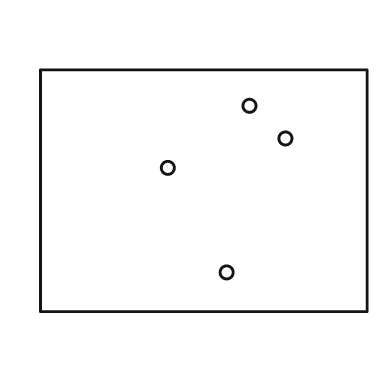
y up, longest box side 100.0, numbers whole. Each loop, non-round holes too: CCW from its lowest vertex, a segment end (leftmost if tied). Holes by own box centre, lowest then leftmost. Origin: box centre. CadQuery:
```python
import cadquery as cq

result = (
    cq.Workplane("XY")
    .moveTo(-50.0, -37.0)
    .lineTo(50.0, -37.0)
    .lineTo(50.0, 37.0)
    .lineTo(-50.0, 37.0)
    .close()
    .moveTo(7.0, -25.0)
    .circle(2.0)
    .moveTo(-11.0, 7.0)
    .circle(2.0)
    .moveTo(25.0, 16.0)
    .circle(2.0)
    .moveTo(14.0, 26.0)
    .circle(2.0)
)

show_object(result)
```